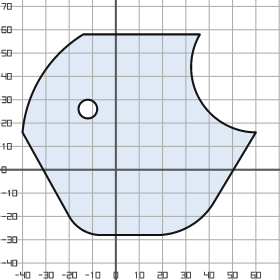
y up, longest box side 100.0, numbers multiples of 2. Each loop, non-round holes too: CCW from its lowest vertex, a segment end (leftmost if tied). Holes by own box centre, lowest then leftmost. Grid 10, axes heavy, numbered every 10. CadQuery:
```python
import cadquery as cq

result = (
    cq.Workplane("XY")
    .moveTo(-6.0, -28.0)
    .lineTo(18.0, -28.0)
    .threePointArc((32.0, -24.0), (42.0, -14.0))
    .lineTo(60.0, 16.0)
    .threePointArc((36.0, 30.0), (36.0, 58.0))
    .lineTo(-14.0, 58.0)
    .threePointArc((-32.0, 40.0), (-40.0, 16.0))
    .lineTo(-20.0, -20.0)
    .threePointArc((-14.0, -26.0), (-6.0, -28.0))
    .close()
    .moveTo(-12.0, 26.0)
    .circle(4.0)
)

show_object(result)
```